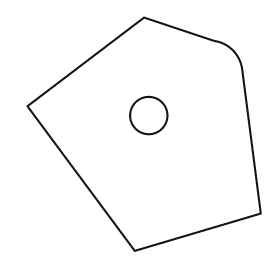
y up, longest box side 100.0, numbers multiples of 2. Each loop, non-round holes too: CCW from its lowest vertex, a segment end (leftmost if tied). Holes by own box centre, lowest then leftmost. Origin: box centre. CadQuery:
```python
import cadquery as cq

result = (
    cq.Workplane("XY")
    .moveTo(-4.0, -50.0)
    .lineTo(50.0, -34.0)
    .lineTo(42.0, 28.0)
    .threePointArc((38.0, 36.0), (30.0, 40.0))
    .lineTo(0.0, 50.0)
    .lineTo(-50.0, 12.0)
    .close()
    .moveTo(2.0, 8.0)
    .circle(8.0)
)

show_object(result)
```